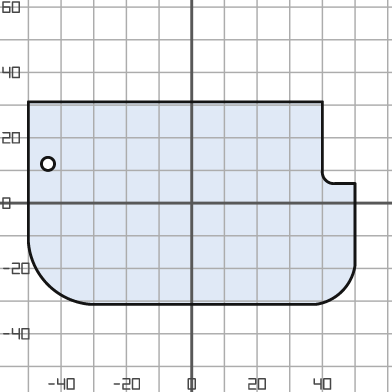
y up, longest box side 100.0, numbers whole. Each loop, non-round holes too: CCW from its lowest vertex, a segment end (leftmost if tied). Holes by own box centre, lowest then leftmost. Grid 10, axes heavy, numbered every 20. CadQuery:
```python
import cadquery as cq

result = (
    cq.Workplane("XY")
    .moveTo(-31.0, -31.0)
    .lineTo(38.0, -31.0)
    .threePointArc((46.0, -27.0), (50.0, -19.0))
    .lineTo(50.0, 6.0)
    .lineTo(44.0, 6.0)
    .threePointArc((41.0, 7.0), (40.0, 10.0))
    .lineTo(40.0, 31.0)
    .lineTo(-50.0, 31.0)
    .lineTo(-50.0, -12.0)
    .threePointArc((-44.0, -25.0), (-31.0, -31.0))
    .close()
    .moveTo(-44.0, 12.0)
    .circle(2.0)
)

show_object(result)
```